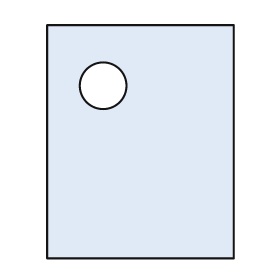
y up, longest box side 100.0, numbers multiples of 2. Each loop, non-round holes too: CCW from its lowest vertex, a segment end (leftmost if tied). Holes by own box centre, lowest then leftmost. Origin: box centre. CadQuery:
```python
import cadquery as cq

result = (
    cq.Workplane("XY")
    .moveTo(-40.0, -50.0)
    .lineTo(40.0, -50.0)
    .lineTo(40.0, 50.0)
    .lineTo(-40.0, 50.0)
    .close()
    .moveTo(-16.0, 24.0)
    .circle(10.0)
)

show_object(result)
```